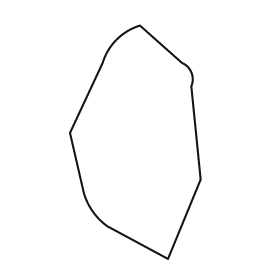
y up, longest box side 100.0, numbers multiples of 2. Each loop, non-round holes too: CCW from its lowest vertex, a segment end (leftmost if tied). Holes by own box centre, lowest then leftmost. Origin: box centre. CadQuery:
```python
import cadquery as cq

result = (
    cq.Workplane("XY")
    .moveTo(14.0, -50.0)
    .lineTo(28.0, -16.0)
    .lineTo(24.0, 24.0)
    .threePointArc((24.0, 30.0), (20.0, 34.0))
    .lineTo(2.0, 50.0)
    .threePointArc((-8.0, 44.0), (-14.0, 34.0))
    .lineTo(-28.0, 4.0)
    .lineTo(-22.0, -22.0)
    .threePointArc((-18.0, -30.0), (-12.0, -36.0))
    .close()
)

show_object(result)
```